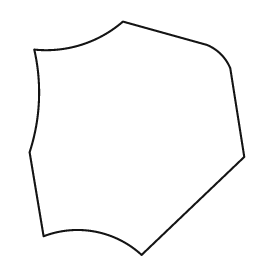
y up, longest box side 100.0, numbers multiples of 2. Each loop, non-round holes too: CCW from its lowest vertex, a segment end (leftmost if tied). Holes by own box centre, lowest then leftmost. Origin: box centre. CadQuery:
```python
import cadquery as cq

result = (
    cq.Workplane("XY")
    .moveTo(2.0, -50.0)
    .lineTo(46.0, -8.0)
    .lineTo(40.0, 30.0)
    .threePointArc((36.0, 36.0), (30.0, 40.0))
    .lineTo(-6.0, 50.0)
    .threePointArc((-24.0, 40.0), (-44.0, 38.0))
    .threePointArc((-42.0, 16.0), (-46.0, -6.0))
    .lineTo(-40.0, -42.0)
    .threePointArc((-18.0, -40.0), (2.0, -50.0))
    .close()
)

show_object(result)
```